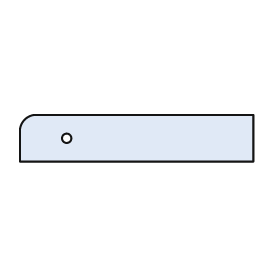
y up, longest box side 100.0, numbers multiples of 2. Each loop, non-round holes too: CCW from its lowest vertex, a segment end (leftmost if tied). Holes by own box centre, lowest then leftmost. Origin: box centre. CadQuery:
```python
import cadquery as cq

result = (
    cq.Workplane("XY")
    .moveTo(-50.0, -10.0)
    .lineTo(50.0, -10.0)
    .lineTo(50.0, 10.0)
    .lineTo(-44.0, 10.0)
    .threePointArc((-48.0, 8.0), (-50.0, 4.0))
    .close()
    .moveTo(-30.0, 0.0)
    .circle(2.0)
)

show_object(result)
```